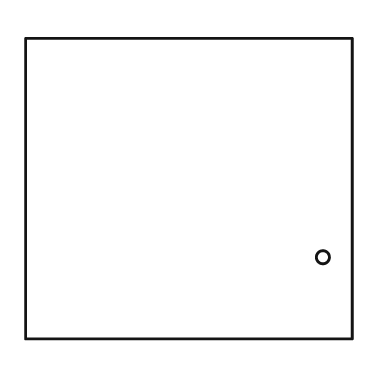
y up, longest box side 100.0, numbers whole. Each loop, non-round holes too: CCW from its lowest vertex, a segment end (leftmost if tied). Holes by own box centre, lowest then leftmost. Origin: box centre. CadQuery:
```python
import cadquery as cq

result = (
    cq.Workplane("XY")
    .moveTo(-50.0, -46.0)
    .lineTo(50.0, -46.0)
    .lineTo(50.0, 46.0)
    .lineTo(-50.0, 46.0)
    .close()
    .moveTo(41.0, -21.0)
    .circle(2.0)
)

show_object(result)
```